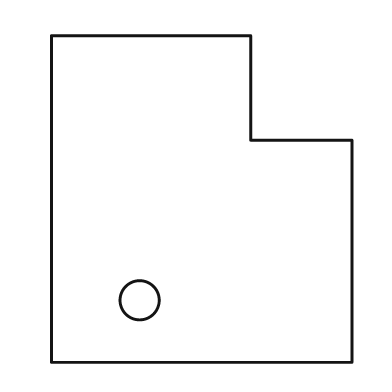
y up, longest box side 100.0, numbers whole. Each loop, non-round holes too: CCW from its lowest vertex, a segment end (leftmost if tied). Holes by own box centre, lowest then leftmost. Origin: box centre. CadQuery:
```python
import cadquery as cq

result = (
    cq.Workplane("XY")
    .moveTo(-46.0, -50.0)
    .lineTo(46.0, -50.0)
    .lineTo(46.0, 18.0)
    .lineTo(15.0, 18.0)
    .lineTo(15.0, 50.0)
    .lineTo(-46.0, 50.0)
    .close()
    .moveTo(-19.0, -31.0)
    .circle(6.0)
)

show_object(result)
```